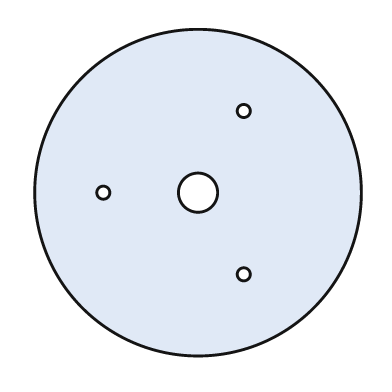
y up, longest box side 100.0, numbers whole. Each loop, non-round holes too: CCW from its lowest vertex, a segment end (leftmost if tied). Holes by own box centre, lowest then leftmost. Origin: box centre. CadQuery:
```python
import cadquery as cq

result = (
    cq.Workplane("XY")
    .moveTo(0.0, 0.0)
    .circle(50.0)
    .moveTo(14.0, -25.0)
    .circle(2.0)
    .moveTo(-29.0, 0.0)
    .circle(2.0)
    .moveTo(0.0, 0.0)
    .circle(6.0)
    .moveTo(14.0, 25.0)
    .circle(2.0)
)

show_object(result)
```